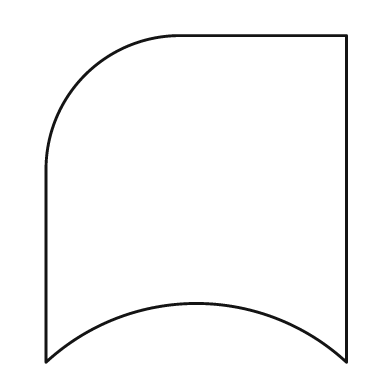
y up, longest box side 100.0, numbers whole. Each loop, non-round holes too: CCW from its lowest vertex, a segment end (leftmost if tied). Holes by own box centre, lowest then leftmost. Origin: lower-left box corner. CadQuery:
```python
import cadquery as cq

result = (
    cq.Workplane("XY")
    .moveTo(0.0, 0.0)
    .threePointArc((46.0, 18.0), (92.0, 0.0))
    .lineTo(92.0, 100.0)
    .lineTo(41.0, 100.0)
    .threePointArc((12.0, 88.0), (0.0, 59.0))
    .close()
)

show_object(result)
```